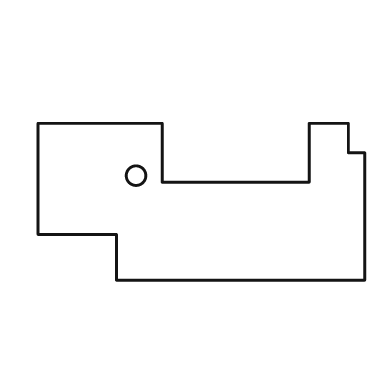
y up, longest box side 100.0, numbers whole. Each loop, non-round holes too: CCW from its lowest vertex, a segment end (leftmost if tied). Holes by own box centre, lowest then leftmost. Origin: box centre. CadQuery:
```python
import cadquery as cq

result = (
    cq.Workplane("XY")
    .moveTo(-26.0, -24.0)
    .lineTo(50.0, -24.0)
    .lineTo(50.0, 15.0)
    .lineTo(45.0, 15.0)
    .lineTo(45.0, 24.0)
    .lineTo(33.0, 24.0)
    .lineTo(33.0, 6.0)
    .lineTo(-12.0, 6.0)
    .lineTo(-12.0, 24.0)
    .lineTo(-50.0, 24.0)
    .lineTo(-50.0, -10.0)
    .lineTo(-26.0, -10.0)
    .close()
    .moveTo(-20.0, 8.0)
    .circle(3.0)
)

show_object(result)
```